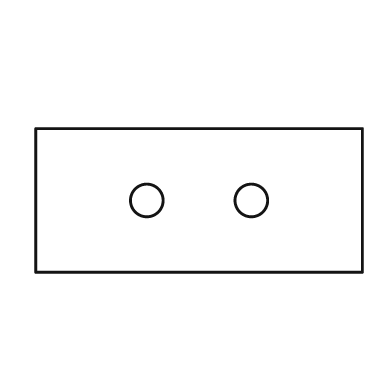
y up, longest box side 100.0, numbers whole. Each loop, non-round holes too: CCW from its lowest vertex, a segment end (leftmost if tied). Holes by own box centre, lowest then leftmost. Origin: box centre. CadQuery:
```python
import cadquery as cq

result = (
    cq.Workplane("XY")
    .moveTo(-50.0, -22.0)
    .lineTo(50.0, -22.0)
    .lineTo(50.0, 22.0)
    .lineTo(-50.0, 22.0)
    .close()
    .moveTo(-16.0, 0.0)
    .circle(5.0)
    .moveTo(16.0, 0.0)
    .circle(5.0)
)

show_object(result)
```